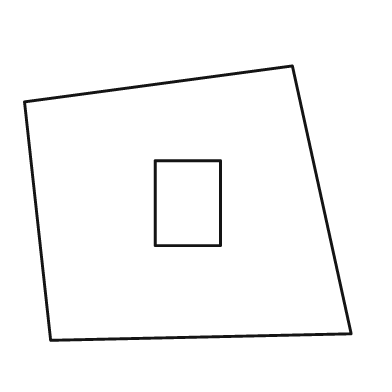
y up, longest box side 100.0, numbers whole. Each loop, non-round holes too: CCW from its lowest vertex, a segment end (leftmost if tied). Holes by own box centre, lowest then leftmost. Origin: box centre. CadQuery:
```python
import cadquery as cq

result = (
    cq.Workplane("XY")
    .moveTo(-42.0, -42.0)
    .lineTo(50.0, -40.0)
    .lineTo(32.0, 42.0)
    .lineTo(-50.0, 31.0)
    .close()
    .moveTo(-10.0, -13.0)
    .lineTo(10.0, -13.0)
    .lineTo(10.0, 13.0)
    .lineTo(-10.0, 13.0)
    .close()
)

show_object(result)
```